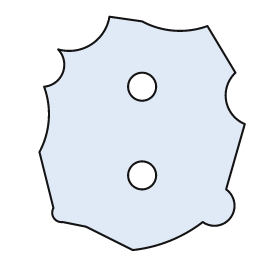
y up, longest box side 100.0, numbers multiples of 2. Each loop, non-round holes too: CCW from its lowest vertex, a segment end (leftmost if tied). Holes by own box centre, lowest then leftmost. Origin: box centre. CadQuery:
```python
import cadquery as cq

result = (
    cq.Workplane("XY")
    .moveTo(-4.0, -50.0)
    .threePointArc((12.0, -46.0), (26.0, -38.0))
    .threePointArc((38.0, -36.0), (36.0, -24.0))
    .lineTo(44.0, 4.0)
    .threePointArc((36.0, 14.0), (40.0, 26.0))
    .lineTo(28.0, 46.0)
    .threePointArc((14.0, 44.0), (0.0, 48.0))
    .lineTo(-14.0, 50.0)
    .threePointArc((-22.0, 38.0), (-36.0, 36.0))
    .threePointArc((-34.0, 26.0), (-42.0, 20.0))
    .threePointArc((-40.0, 6.0), (-44.0, -8.0))
    .lineTo(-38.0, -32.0)
    .threePointArc((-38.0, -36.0), (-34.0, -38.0))
    .lineTo(-24.0, -40.0)
    .close()
    .moveTo(0.0, -18.0)
    .circle(6.0)
    .moveTo(0.0, 20.0)
    .circle(6.0)
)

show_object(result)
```